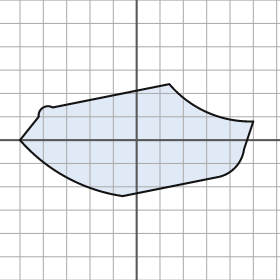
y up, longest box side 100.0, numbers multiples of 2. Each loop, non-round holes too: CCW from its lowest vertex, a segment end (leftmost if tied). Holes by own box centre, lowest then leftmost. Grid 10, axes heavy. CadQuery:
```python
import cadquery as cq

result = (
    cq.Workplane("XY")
    .moveTo(-6.0, -24.0)
    .lineTo(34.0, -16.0)
    .threePointArc((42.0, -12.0), (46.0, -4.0))
    .lineTo(50.0, 8.0)
    .threePointArc((30.0, 12.0), (14.0, 24.0))
    .lineTo(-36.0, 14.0)
    .threePointArc((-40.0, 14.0), (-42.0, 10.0))
    .lineTo(-50.0, 0.0)
    .threePointArc((-30.0, -16.0), (-6.0, -24.0))
    .close()
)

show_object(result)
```